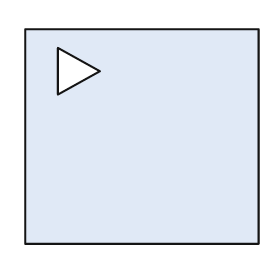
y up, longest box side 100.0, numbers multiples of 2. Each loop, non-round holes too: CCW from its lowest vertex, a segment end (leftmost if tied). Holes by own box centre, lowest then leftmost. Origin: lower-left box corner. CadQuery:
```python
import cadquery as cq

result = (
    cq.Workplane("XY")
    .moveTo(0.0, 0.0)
    .lineTo(100.0, 0.0)
    .lineTo(100.0, 92.0)
    .lineTo(0.0, 92.0)
    .close()
    .moveTo(14.0, 64.0)
    .lineTo(32.0, 74.0)
    .lineTo(14.0, 84.0)
    .close()
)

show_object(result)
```